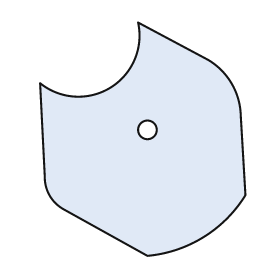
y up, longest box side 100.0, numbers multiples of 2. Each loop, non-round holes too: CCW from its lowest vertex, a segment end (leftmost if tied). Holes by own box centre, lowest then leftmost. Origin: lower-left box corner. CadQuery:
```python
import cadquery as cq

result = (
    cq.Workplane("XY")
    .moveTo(46.0, 0.0)
    .threePointArc((70.0, 8.0), (88.0, 26.0))
    .lineTo(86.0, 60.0)
    .threePointArc((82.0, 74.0), (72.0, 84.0))
    .lineTo(42.0, 100.0)
    .threePointArc((30.0, 72.0), (0.0, 74.0))
    .lineTo(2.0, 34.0)
    .threePointArc((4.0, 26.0), (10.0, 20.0))
    .close()
    .moveTo(46.0, 54.0)
    .circle(4.0)
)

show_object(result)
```